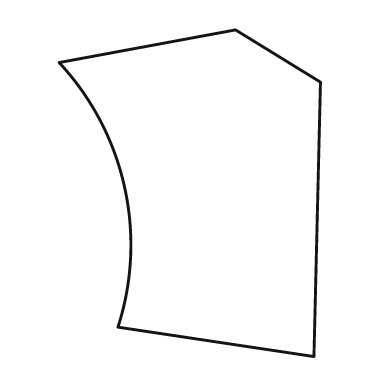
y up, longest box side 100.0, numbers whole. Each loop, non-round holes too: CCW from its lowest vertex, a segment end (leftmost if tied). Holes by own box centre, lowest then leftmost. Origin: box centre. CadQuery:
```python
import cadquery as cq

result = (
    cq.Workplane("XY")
    .moveTo(38.0, -50.0)
    .lineTo(40.0, 34.0)
    .lineTo(14.0, 50.0)
    .lineTo(-40.0, 40.0)
    .threePointArc((-20.0, 2.0), (-22.0, -41.0))
    .close()
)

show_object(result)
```